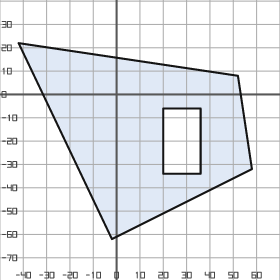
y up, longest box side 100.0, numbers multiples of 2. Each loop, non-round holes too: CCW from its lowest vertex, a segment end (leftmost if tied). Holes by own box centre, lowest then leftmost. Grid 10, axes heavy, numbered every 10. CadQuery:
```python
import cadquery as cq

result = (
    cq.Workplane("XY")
    .moveTo(-2.0, -62.0)
    .lineTo(58.0, -32.0)
    .lineTo(52.0, 8.0)
    .lineTo(-42.0, 22.0)
    .close()
    .moveTo(20.0, -34.0)
    .lineTo(36.0, -34.0)
    .lineTo(36.0, -6.0)
    .lineTo(20.0, -6.0)
    .close()
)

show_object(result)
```